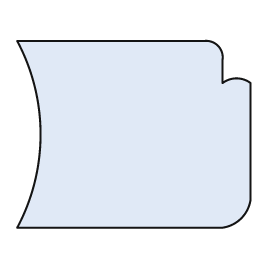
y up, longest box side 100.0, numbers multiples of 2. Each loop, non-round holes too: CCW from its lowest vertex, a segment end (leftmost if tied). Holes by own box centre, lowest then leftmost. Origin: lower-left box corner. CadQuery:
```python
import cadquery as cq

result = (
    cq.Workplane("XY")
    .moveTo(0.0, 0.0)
    .lineTo(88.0, 0.0)
    .threePointArc((96.0, 4.0), (100.0, 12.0))
    .lineTo(100.0, 62.0)
    .threePointArc((94.0, 64.0), (88.0, 62.0))
    .lineTo(88.0, 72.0)
    .threePointArc((86.0, 78.0), (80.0, 80.0))
    .lineTo(0.0, 80.0)
    .threePointArc((10.0, 40.0), (0.0, 0.0))
    .close()
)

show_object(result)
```